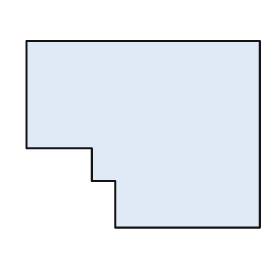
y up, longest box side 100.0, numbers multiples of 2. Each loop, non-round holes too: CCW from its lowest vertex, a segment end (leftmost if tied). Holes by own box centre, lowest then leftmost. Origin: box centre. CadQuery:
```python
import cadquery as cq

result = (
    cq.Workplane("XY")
    .moveTo(-12.0, -40.0)
    .lineTo(50.0, -40.0)
    .lineTo(50.0, 40.0)
    .lineTo(-50.0, 40.0)
    .lineTo(-50.0, -6.0)
    .lineTo(-22.0, -6.0)
    .lineTo(-22.0, -20.0)
    .lineTo(-12.0, -20.0)
    .close()
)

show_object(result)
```